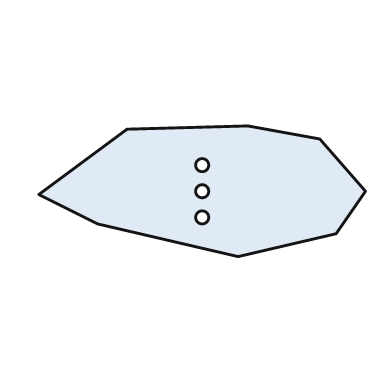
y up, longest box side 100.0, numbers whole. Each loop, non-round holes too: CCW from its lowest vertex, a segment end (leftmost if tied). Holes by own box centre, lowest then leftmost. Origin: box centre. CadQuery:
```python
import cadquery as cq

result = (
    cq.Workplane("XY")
    .moveTo(11.0, -20.0)
    .lineTo(41.0, -13.0)
    .lineTo(50.0, 0.0)
    .lineTo(36.0, 16.0)
    .lineTo(14.0, 20.0)
    .lineTo(-23.0, 19.0)
    .lineTo(-50.0, -1.0)
    .lineTo(-32.0, -10.0)
    .close()
    .moveTo(0.0, -8.0)
    .circle(2.0)
    .moveTo(0.0, 0.0)
    .circle(2.0)
    .moveTo(0.0, 8.0)
    .circle(2.0)
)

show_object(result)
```